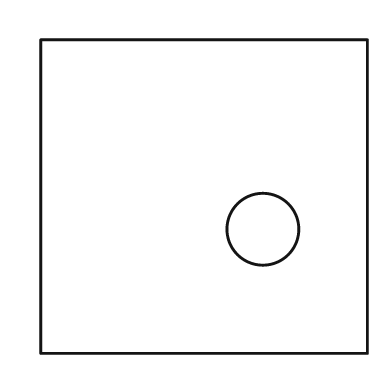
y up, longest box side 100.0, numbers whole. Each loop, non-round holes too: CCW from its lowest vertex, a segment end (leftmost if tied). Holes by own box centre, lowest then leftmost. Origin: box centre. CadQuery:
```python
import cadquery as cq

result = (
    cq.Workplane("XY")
    .moveTo(-50.0, -48.0)
    .lineTo(50.0, -48.0)
    .lineTo(50.0, 48.0)
    .lineTo(-50.0, 48.0)
    .close()
    .moveTo(18.0, -10.0)
    .circle(11.0)
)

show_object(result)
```